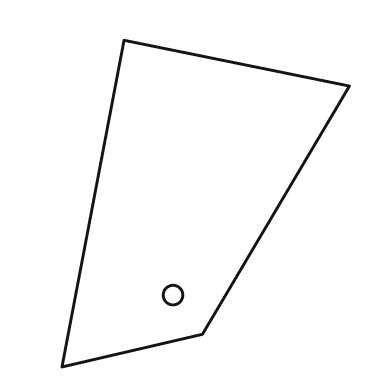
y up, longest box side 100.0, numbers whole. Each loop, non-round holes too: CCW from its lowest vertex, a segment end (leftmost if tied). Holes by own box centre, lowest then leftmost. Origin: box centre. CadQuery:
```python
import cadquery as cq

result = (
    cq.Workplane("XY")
    .moveTo(-44.0, -50.0)
    .lineTo(-1.0, -40.0)
    .lineTo(44.0, 36.0)
    .lineTo(-25.0, 50.0)
    .close()
    .moveTo(-10.0, -28.0)
    .circle(3.0)
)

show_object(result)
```